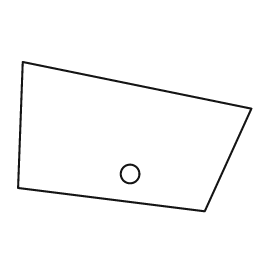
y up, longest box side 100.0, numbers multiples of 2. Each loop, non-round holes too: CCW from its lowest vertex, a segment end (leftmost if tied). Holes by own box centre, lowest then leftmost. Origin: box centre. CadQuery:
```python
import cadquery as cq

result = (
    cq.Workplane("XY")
    .moveTo(30.0, -32.0)
    .lineTo(50.0, 12.0)
    .lineTo(-48.0, 32.0)
    .lineTo(-50.0, -22.0)
    .close()
    .moveTo(-2.0, -16.0)
    .circle(4.0)
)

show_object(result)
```